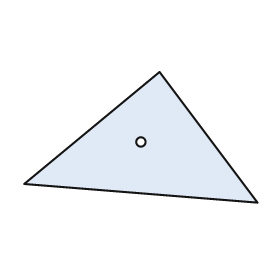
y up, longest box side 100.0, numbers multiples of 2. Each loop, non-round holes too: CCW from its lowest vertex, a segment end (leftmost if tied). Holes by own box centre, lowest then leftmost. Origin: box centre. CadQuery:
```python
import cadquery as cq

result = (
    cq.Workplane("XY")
    .moveTo(50.0, -28.0)
    .lineTo(8.0, 28.0)
    .lineTo(-50.0, -20.0)
    .close()
    .moveTo(0.0, -2.0)
    .circle(2.0)
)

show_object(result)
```